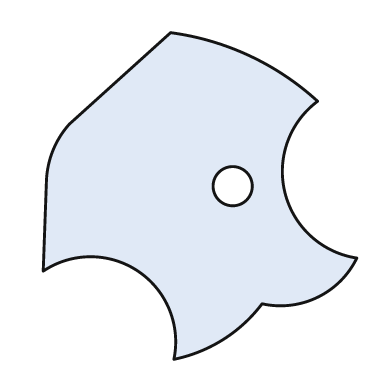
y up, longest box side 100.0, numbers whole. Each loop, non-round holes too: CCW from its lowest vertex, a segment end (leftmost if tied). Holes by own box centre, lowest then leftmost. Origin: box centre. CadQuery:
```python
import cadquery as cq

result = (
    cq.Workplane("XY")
    .moveTo(-8.0, -50.0)
    .threePointArc((7.0, -44.0), (19.0, -33.0))
    .threePointArc((36.0, -31.0), (48.0, -19.0))
    .threePointArc((26.0, 1.0), (36.0, 29.0))
    .threePointArc((15.0, 43.0), (-9.0, 50.0))
    .lineTo(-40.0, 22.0)
    .threePointArc((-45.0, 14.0), (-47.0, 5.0))
    .lineTo(-48.0, -23.0)
    .threePointArc((-19.0, -23.0), (-8.0, -50.0))
    .close()
    .moveTo(10.0, 3.0)
    .circle(6.0)
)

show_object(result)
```